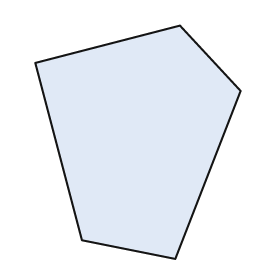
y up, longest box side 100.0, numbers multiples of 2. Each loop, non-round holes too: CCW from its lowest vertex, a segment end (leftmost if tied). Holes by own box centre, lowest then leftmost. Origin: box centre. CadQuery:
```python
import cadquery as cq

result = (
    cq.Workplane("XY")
    .moveTo(16.0, -50.0)
    .lineTo(44.0, 22.0)
    .lineTo(18.0, 50.0)
    .lineTo(-44.0, 34.0)
    .lineTo(-24.0, -42.0)
    .close()
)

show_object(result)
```